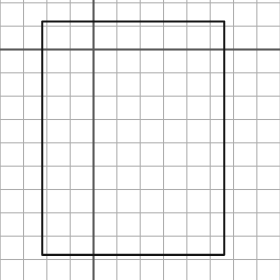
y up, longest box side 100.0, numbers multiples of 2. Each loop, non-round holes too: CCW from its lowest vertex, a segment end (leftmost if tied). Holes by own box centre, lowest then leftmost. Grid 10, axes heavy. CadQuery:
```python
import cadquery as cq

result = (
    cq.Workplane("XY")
    .moveTo(-22.0, -88.0)
    .lineTo(56.0, -88.0)
    .lineTo(56.0, 12.0)
    .lineTo(-22.0, 12.0)
    .close()
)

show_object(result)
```